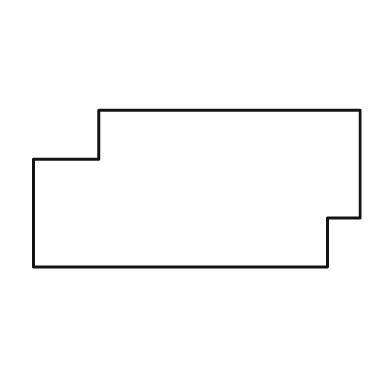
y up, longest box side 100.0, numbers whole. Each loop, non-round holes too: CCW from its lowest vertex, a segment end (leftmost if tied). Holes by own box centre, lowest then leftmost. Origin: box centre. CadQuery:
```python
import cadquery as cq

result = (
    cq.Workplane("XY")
    .moveTo(-50.0, -24.0)
    .lineTo(40.0, -24.0)
    .lineTo(40.0, -9.0)
    .lineTo(50.0, -9.0)
    .lineTo(50.0, 24.0)
    .lineTo(-30.0, 24.0)
    .lineTo(-30.0, 9.0)
    .lineTo(-50.0, 9.0)
    .close()
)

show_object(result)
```